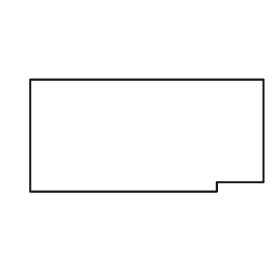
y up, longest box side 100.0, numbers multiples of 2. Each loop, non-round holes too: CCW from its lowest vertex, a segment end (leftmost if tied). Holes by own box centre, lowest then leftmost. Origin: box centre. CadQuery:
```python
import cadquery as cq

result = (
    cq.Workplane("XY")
    .moveTo(-50.0, -24.0)
    .lineTo(30.0, -24.0)
    .lineTo(30.0, -20.0)
    .lineTo(50.0, -20.0)
    .lineTo(50.0, 24.0)
    .lineTo(-50.0, 24.0)
    .close()
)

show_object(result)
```